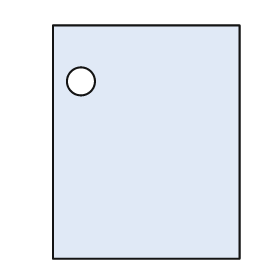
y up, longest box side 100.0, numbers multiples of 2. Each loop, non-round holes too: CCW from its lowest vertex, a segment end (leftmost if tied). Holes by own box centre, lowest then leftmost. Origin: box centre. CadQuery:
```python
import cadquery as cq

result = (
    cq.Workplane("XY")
    .moveTo(-40.0, -50.0)
    .lineTo(40.0, -50.0)
    .lineTo(40.0, 50.0)
    .lineTo(-40.0, 50.0)
    .close()
    .moveTo(-28.0, 26.0)
    .circle(6.0)
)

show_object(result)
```